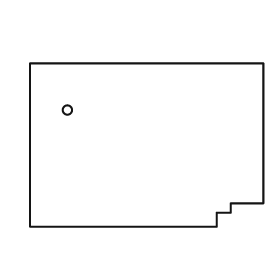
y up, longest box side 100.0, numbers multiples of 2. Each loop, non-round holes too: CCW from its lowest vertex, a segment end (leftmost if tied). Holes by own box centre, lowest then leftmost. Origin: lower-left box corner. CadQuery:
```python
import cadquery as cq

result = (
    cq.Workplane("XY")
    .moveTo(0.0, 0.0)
    .lineTo(80.0, 0.0)
    .lineTo(80.0, 6.0)
    .lineTo(86.0, 6.0)
    .lineTo(86.0, 10.0)
    .lineTo(100.0, 10.0)
    .lineTo(100.0, 70.0)
    .lineTo(0.0, 70.0)
    .close()
    .moveTo(16.0, 50.0)
    .circle(2.0)
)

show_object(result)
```